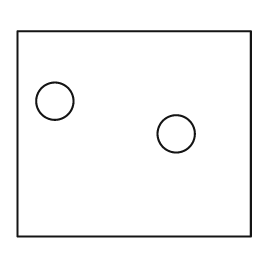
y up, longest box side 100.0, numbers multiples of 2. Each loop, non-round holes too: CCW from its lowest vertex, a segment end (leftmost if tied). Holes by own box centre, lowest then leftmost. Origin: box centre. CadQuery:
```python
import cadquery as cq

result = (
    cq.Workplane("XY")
    .moveTo(-50.0, -44.0)
    .lineTo(50.0, -44.0)
    .lineTo(50.0, 44.0)
    .lineTo(-50.0, 44.0)
    .close()
    .moveTo(18.0, 0.0)
    .circle(8.0)
    .moveTo(-34.0, 14.0)
    .circle(8.0)
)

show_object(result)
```